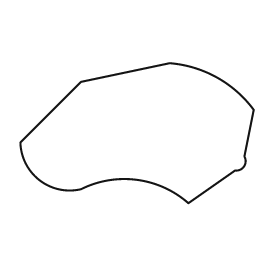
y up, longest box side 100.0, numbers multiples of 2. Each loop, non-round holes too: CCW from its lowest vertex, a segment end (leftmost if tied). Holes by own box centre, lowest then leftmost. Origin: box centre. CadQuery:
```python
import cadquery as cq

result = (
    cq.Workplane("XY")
    .moveTo(22.0, -30.0)
    .lineTo(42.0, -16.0)
    .threePointArc((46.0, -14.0), (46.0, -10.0))
    .lineTo(50.0, 10.0)
    .threePointArc((34.0, 24.0), (14.0, 30.0))
    .lineTo(-24.0, 22.0)
    .lineTo(-50.0, -4.0)
    .threePointArc((-42.0, -20.0), (-24.0, -24.0))
    .threePointArc((0.0, -20.0), (22.0, -30.0))
    .close()
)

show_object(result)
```